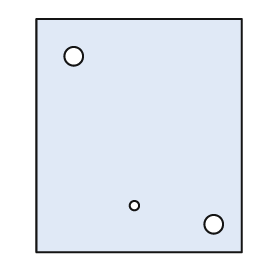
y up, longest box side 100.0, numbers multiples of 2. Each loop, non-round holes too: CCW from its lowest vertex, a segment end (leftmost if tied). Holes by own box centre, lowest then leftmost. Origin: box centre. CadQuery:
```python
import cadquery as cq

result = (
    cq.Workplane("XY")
    .moveTo(-44.0, -50.0)
    .lineTo(44.0, -50.0)
    .lineTo(44.0, 50.0)
    .lineTo(-44.0, 50.0)
    .close()
    .moveTo(32.0, -38.0)
    .circle(4.0)
    .moveTo(-2.0, -30.0)
    .circle(2.0)
    .moveTo(-28.0, 34.0)
    .circle(4.0)
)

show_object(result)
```